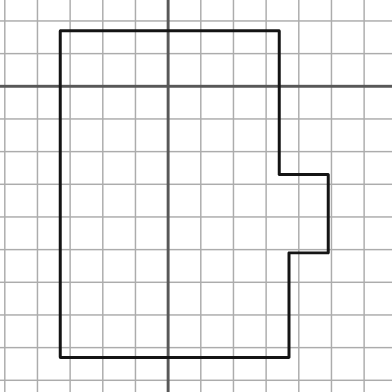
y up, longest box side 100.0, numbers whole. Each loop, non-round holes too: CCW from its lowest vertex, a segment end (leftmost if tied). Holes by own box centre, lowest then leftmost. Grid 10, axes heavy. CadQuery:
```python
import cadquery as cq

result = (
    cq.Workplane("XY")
    .moveTo(-33.0, -83.0)
    .lineTo(37.0, -83.0)
    .lineTo(37.0, -51.0)
    .lineTo(49.0, -51.0)
    .lineTo(49.0, -27.0)
    .lineTo(34.0, -27.0)
    .lineTo(34.0, 17.0)
    .lineTo(-33.0, 17.0)
    .close()
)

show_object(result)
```